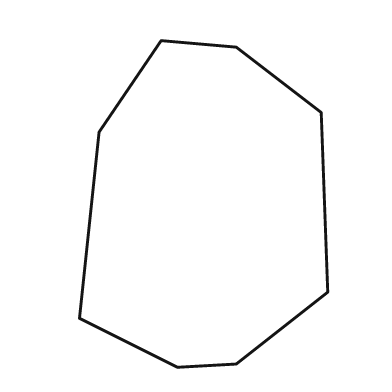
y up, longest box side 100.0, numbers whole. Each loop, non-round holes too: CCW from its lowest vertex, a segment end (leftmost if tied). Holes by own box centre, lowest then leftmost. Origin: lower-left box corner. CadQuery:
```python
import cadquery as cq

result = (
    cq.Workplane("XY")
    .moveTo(30.0, 0.0)
    .lineTo(48.0, 1.0)
    .lineTo(76.0, 23.0)
    .lineTo(74.0, 78.0)
    .lineTo(48.0, 98.0)
    .lineTo(25.0, 100.0)
    .lineTo(6.0, 72.0)
    .lineTo(0.0, 15.0)
    .close()
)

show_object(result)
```